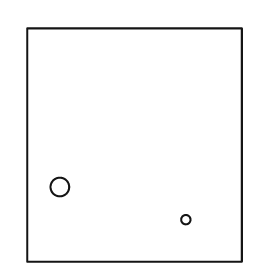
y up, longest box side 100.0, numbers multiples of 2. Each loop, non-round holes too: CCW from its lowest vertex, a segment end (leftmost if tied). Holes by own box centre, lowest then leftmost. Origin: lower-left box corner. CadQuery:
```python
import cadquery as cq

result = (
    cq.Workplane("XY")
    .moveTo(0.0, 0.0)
    .lineTo(92.0, 0.0)
    .lineTo(92.0, 100.0)
    .lineTo(0.0, 100.0)
    .close()
    .moveTo(68.0, 18.0)
    .circle(2.0)
    .moveTo(14.0, 32.0)
    .circle(4.0)
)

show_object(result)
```